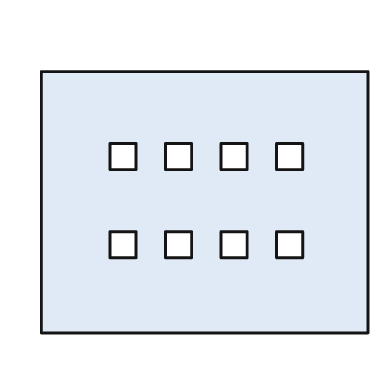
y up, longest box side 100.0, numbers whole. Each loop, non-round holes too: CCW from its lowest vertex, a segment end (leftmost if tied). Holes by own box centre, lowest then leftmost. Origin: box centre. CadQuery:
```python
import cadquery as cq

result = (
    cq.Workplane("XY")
    .moveTo(-50.0, -40.0)
    .lineTo(50.0, -40.0)
    .lineTo(50.0, 40.0)
    .lineTo(-50.0, 40.0)
    .close()
    .moveTo(-29.0, -17.0)
    .lineTo(-21.0, -17.0)
    .lineTo(-21.0, -9.0)
    .lineTo(-29.0, -9.0)
    .close()
    .moveTo(-12.0, -17.0)
    .lineTo(-4.0, -17.0)
    .lineTo(-4.0, -9.0)
    .lineTo(-12.0, -9.0)
    .close()
    .moveTo(5.0, -17.0)
    .lineTo(13.0, -17.0)
    .lineTo(13.0, -9.0)
    .lineTo(5.0, -9.0)
    .close()
    .moveTo(22.0, -17.0)
    .lineTo(30.0, -17.0)
    .lineTo(30.0, -9.0)
    .lineTo(22.0, -9.0)
    .close()
    .moveTo(-29.0, 10.0)
    .lineTo(-21.0, 10.0)
    .lineTo(-21.0, 18.0)
    .lineTo(-29.0, 18.0)
    .close()
    .moveTo(-12.0, 10.0)
    .lineTo(-4.0, 10.0)
    .lineTo(-4.0, 18.0)
    .lineTo(-12.0, 18.0)
    .close()
    .moveTo(5.0, 10.0)
    .lineTo(13.0, 10.0)
    .lineTo(13.0, 18.0)
    .lineTo(5.0, 18.0)
    .close()
    .moveTo(22.0, 10.0)
    .lineTo(30.0, 10.0)
    .lineTo(30.0, 18.0)
    .lineTo(22.0, 18.0)
    .close()
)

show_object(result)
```